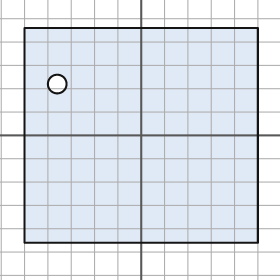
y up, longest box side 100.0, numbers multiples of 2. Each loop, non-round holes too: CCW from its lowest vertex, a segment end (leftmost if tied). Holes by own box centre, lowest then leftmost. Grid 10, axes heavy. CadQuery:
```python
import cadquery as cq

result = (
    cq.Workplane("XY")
    .moveTo(-50.0, -46.0)
    .lineTo(50.0, -46.0)
    .lineTo(50.0, 46.0)
    .lineTo(-50.0, 46.0)
    .close()
    .moveTo(-36.0, 22.0)
    .circle(4.0)
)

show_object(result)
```